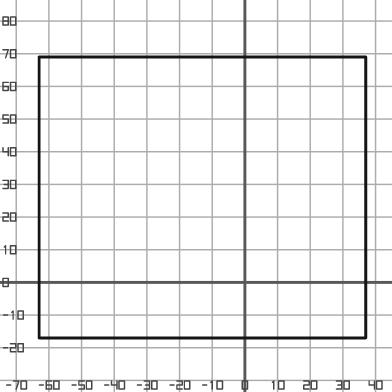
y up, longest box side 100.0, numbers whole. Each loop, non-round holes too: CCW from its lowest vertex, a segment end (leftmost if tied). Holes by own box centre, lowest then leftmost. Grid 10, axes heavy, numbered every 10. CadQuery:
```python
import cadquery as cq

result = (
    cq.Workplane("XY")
    .moveTo(-63.0, -17.0)
    .lineTo(37.0, -17.0)
    .lineTo(37.0, 69.0)
    .lineTo(-63.0, 69.0)
    .close()
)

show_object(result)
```